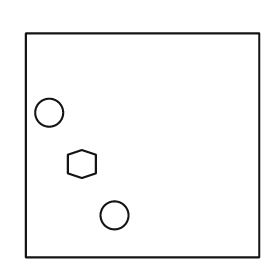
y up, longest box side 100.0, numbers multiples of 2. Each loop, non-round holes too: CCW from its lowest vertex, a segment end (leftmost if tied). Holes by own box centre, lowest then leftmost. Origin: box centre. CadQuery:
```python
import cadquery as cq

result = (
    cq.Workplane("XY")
    .moveTo(-50.0, -48.0)
    .lineTo(50.0, -48.0)
    .lineTo(50.0, 48.0)
    .lineTo(-50.0, 48.0)
    .close()
    .moveTo(-12.0, -30.0)
    .circle(6.0)
    .moveTo(-26.0, -14.0)
    .lineTo(-20.0, -12.0)
    .lineTo(-20.0, -4.0)
    .lineTo(-26.0, -2.0)
    .lineTo(-32.0, -4.0)
    .lineTo(-32.0, -12.0)
    .close()
    .moveTo(-40.0, 14.0)
    .circle(6.0)
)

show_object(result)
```